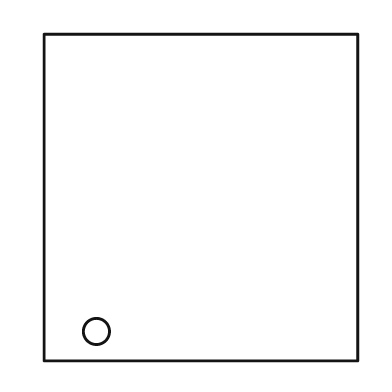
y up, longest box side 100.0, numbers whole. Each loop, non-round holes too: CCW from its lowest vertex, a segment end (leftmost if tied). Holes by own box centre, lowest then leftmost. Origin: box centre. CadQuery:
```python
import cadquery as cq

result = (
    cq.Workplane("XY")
    .moveTo(-48.0, -50.0)
    .lineTo(48.0, -50.0)
    .lineTo(48.0, 50.0)
    .lineTo(-48.0, 50.0)
    .close()
    .moveTo(-32.0, -41.0)
    .circle(4.0)
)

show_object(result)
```